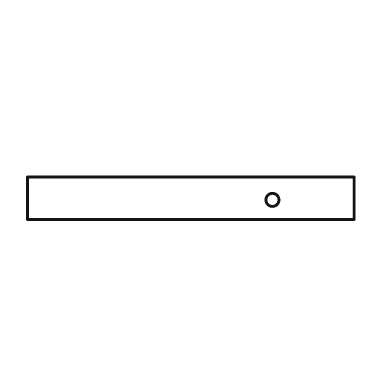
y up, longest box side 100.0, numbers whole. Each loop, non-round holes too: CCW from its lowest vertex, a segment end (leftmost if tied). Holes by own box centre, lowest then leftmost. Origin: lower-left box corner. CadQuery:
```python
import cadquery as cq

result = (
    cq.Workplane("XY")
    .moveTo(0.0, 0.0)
    .lineTo(100.0, 0.0)
    .lineTo(100.0, 13.0)
    .lineTo(0.0, 13.0)
    .close()
    .moveTo(75.0, 6.0)
    .circle(2.0)
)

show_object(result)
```